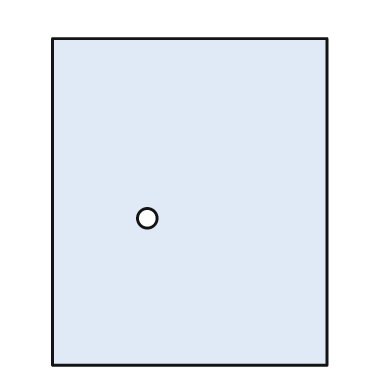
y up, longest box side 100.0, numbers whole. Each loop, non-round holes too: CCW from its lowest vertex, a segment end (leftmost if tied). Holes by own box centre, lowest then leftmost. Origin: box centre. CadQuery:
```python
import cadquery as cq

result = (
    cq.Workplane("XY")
    .moveTo(-42.0, -50.0)
    .lineTo(42.0, -50.0)
    .lineTo(42.0, 50.0)
    .lineTo(-42.0, 50.0)
    .close()
    .moveTo(-13.0, -5.0)
    .circle(3.0)
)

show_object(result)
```